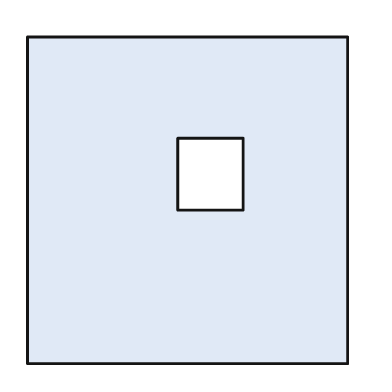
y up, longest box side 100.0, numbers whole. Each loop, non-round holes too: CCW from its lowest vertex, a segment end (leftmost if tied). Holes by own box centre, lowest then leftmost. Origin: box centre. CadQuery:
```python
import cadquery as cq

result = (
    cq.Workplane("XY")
    .moveTo(-49.0, -50.0)
    .lineTo(49.0, -50.0)
    .lineTo(49.0, 50.0)
    .lineTo(-49.0, 50.0)
    .close()
    .moveTo(-3.0, -3.0)
    .lineTo(17.0, -3.0)
    .lineTo(17.0, 19.0)
    .lineTo(-3.0, 19.0)
    .close()
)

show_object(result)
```